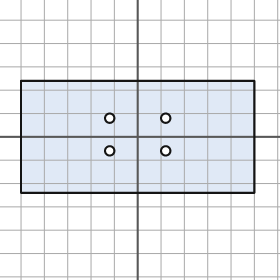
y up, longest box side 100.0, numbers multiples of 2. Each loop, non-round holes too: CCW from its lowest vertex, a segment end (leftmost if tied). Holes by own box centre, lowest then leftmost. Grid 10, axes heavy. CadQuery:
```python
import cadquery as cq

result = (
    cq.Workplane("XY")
    .moveTo(-50.0, -24.0)
    .lineTo(50.0, -24.0)
    .lineTo(50.0, 24.0)
    .lineTo(-50.0, 24.0)
    .close()
    .moveTo(-12.0, -6.0)
    .circle(2.0)
    .moveTo(12.0, -6.0)
    .circle(2.0)
    .moveTo(-12.0, 8.0)
    .circle(2.0)
    .moveTo(12.0, 8.0)
    .circle(2.0)
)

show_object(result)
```